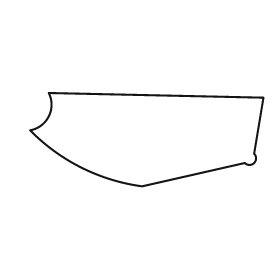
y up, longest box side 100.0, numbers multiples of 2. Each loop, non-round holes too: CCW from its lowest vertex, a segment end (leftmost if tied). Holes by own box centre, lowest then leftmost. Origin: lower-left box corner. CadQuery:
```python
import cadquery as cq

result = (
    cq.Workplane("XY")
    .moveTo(48.0, 0.0)
    .lineTo(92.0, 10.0)
    .threePointArc((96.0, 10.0), (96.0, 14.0))
    .lineTo(100.0, 38.0)
    .lineTo(8.0, 40.0)
    .threePointArc((8.0, 30.0), (0.0, 24.0))
    .threePointArc((22.0, 8.0), (48.0, 0.0))
    .close()
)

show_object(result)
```